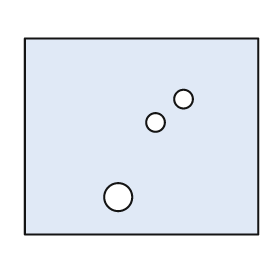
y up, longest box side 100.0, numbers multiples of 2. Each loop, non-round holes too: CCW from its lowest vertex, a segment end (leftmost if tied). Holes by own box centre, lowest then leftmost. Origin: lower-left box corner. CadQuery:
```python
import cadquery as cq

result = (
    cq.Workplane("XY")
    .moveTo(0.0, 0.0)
    .lineTo(100.0, 0.0)
    .lineTo(100.0, 84.0)
    .lineTo(0.0, 84.0)
    .close()
    .moveTo(40.0, 16.0)
    .circle(6.0)
    .moveTo(56.0, 48.0)
    .circle(4.0)
    .moveTo(68.0, 58.0)
    .circle(4.0)
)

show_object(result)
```